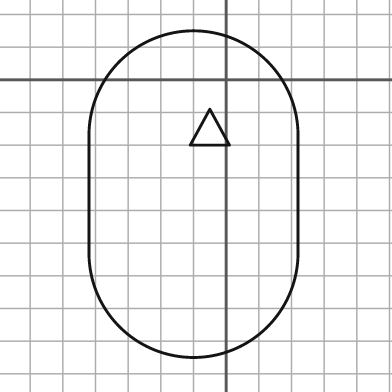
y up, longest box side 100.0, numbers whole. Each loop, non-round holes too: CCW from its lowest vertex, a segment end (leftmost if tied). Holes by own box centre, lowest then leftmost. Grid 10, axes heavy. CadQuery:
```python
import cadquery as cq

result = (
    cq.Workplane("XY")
    .moveTo(-42.0, -53.0)
    .threePointArc((-10.0, -85.0), (22.0, -53.0))
    .lineTo(22.0, -17.0)
    .threePointArc((-10.0, 15.0), (-42.0, -17.0))
    .close()
    .moveTo(-11.0, -20.0)
    .lineTo(1.0, -20.0)
    .lineTo(-5.0, -9.0)
    .close()
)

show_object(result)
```